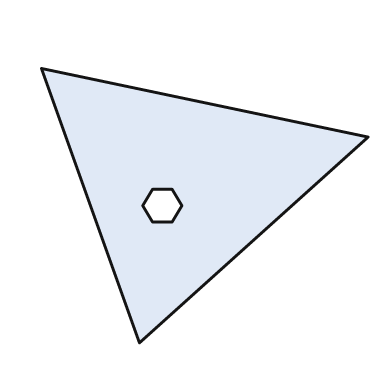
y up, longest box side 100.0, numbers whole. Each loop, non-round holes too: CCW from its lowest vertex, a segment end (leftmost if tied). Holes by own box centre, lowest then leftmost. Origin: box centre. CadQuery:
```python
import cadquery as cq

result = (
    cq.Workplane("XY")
    .moveTo(-20.0, -42.0)
    .lineTo(50.0, 21.0)
    .lineTo(-50.0, 42.0)
    .close()
    .moveTo(-16.0, -5.0)
    .lineTo(-10.0, -5.0)
    .lineTo(-7.0, 0.0)
    .lineTo(-10.0, 5.0)
    .lineTo(-16.0, 5.0)
    .lineTo(-19.0, 0.0)
    .close()
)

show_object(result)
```